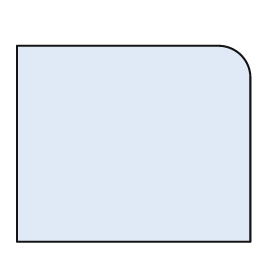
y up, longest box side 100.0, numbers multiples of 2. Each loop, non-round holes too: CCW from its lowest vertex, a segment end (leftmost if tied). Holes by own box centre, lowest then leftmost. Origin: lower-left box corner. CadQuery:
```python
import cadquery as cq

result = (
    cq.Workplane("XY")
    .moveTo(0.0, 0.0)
    .lineTo(100.0, 0.0)
    .lineTo(100.0, 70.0)
    .threePointArc((96.0, 80.0), (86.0, 84.0))
    .lineTo(0.0, 84.0)
    .close()
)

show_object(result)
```